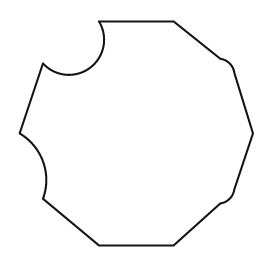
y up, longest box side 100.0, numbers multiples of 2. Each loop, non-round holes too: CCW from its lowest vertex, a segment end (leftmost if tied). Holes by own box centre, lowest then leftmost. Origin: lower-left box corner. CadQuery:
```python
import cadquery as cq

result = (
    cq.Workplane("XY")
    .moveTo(34.0, 0.0)
    .lineTo(66.0, 0.0)
    .lineTo(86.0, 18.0)
    .threePointArc((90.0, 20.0), (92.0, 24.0))
    .lineTo(100.0, 48.0)
    .lineTo(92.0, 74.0)
    .threePointArc((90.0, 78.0), (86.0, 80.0))
    .lineTo(66.0, 96.0)
    .lineTo(34.0, 96.0)
    .threePointArc((30.0, 76.0), (10.0, 78.0))
    .lineTo(0.0, 48.0)
    .threePointArc((10.0, 36.0), (10.0, 20.0))
    .close()
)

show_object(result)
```